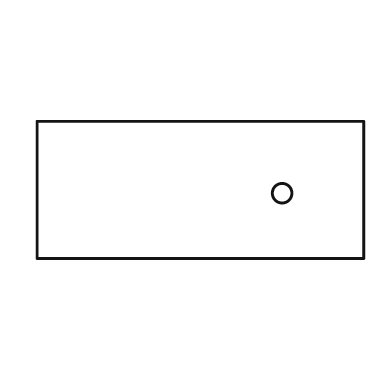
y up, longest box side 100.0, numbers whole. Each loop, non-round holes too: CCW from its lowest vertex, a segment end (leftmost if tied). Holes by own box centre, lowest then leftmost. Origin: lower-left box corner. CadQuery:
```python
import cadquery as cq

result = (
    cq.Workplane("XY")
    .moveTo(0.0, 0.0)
    .lineTo(100.0, 0.0)
    .lineTo(100.0, 42.0)
    .lineTo(0.0, 42.0)
    .close()
    .moveTo(75.0, 20.0)
    .circle(3.0)
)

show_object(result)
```